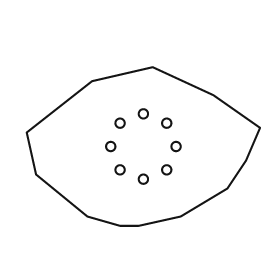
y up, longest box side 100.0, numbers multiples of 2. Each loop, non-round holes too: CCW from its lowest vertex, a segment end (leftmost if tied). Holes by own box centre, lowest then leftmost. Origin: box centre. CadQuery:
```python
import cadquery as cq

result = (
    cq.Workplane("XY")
    .moveTo(-10.0, -34.0)
    .lineTo(-2.0, -34.0)
    .lineTo(16.0, -30.0)
    .lineTo(36.0, -18.0)
    .lineTo(44.0, -6.0)
    .lineTo(50.0, 8.0)
    .lineTo(30.0, 22.0)
    .lineTo(4.0, 34.0)
    .lineTo(-22.0, 28.0)
    .lineTo(-50.0, 6.0)
    .lineTo(-46.0, -12.0)
    .lineTo(-24.0, -30.0)
    .close()
    .moveTo(0.0, -14.0)
    .circle(2.0)
    .moveTo(-10.0, -10.0)
    .circle(2.0)
    .moveTo(10.0, -10.0)
    .circle(2.0)
    .moveTo(-14.0, 0.0)
    .circle(2.0)
    .moveTo(14.0, 0.0)
    .circle(2.0)
    .moveTo(-10.0, 10.0)
    .circle(2.0)
    .moveTo(10.0, 10.0)
    .circle(2.0)
    .moveTo(0.0, 14.0)
    .circle(2.0)
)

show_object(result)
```